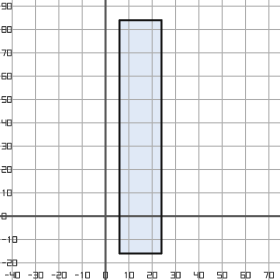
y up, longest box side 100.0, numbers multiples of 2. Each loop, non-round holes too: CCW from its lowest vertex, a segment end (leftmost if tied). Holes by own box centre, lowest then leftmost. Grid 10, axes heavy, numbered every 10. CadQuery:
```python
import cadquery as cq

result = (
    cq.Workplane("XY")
    .moveTo(6.0, -16.0)
    .lineTo(24.0, -16.0)
    .lineTo(24.0, 84.0)
    .lineTo(6.0, 84.0)
    .close()
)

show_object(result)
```